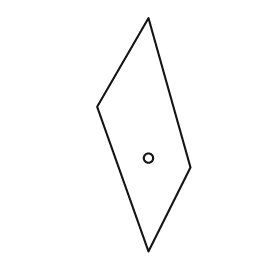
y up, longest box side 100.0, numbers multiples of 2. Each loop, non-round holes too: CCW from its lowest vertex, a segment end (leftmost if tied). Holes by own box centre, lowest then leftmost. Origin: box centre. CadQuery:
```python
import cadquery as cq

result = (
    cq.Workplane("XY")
    .moveTo(2.0, -50.0)
    .lineTo(20.0, -14.0)
    .lineTo(2.0, 50.0)
    .lineTo(-20.0, 12.0)
    .close()
    .moveTo(2.0, -10.0)
    .circle(2.0)
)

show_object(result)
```